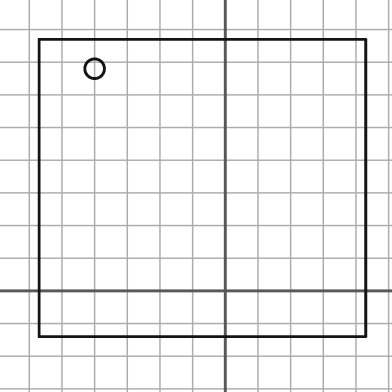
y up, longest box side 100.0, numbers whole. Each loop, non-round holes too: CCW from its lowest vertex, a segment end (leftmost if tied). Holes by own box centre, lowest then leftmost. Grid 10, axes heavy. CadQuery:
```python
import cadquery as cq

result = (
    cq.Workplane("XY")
    .moveTo(-57.0, -14.0)
    .lineTo(43.0, -14.0)
    .lineTo(43.0, 77.0)
    .lineTo(-57.0, 77.0)
    .close()
    .moveTo(-40.0, 68.0)
    .circle(3.0)
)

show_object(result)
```